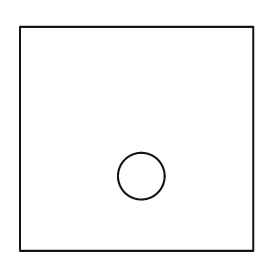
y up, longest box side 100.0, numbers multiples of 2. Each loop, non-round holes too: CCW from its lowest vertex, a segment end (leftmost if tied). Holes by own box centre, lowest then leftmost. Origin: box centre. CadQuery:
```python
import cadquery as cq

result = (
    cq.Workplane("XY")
    .moveTo(-50.0, -48.0)
    .lineTo(50.0, -48.0)
    .lineTo(50.0, 48.0)
    .lineTo(-50.0, 48.0)
    .close()
    .moveTo(2.0, -16.0)
    .circle(10.0)
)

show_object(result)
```